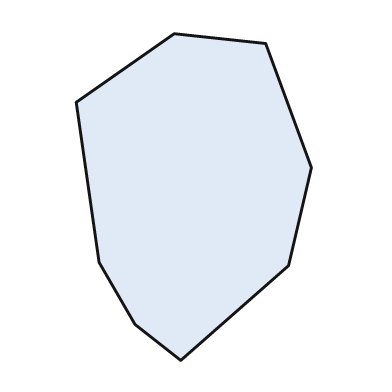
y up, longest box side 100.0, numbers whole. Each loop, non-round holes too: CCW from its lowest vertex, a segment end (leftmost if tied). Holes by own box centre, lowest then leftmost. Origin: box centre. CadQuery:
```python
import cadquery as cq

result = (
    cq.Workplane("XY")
    .moveTo(-4.0, -50.0)
    .lineTo(29.0, -21.0)
    .lineTo(36.0, 9.0)
    .lineTo(22.0, 47.0)
    .lineTo(-6.0, 50.0)
    .lineTo(-36.0, 29.0)
    .lineTo(-29.0, -20.0)
    .lineTo(-18.0, -39.0)
    .close()
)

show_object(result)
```